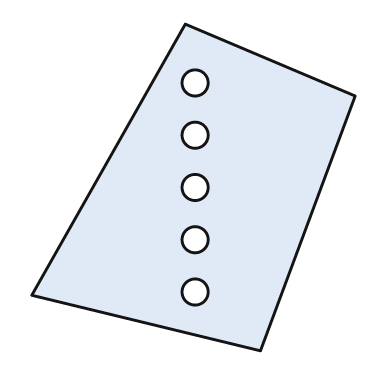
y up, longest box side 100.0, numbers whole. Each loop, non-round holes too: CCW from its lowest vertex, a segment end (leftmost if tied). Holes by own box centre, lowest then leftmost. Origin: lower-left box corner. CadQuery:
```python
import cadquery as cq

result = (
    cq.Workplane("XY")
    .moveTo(70.0, 0.0)
    .lineTo(99.0, 78.0)
    .lineTo(47.0, 100.0)
    .lineTo(0.0, 17.0)
    .close()
    .moveTo(50.0, 18.0)
    .circle(4.0)
    .moveTo(50.0, 34.0)
    .circle(4.0)
    .moveTo(50.0, 50.0)
    .circle(4.0)
    .moveTo(50.0, 66.0)
    .circle(4.0)
    .moveTo(50.0, 82.0)
    .circle(4.0)
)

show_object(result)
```